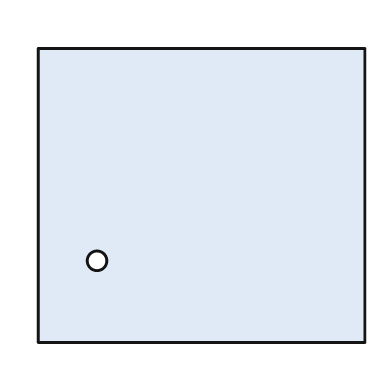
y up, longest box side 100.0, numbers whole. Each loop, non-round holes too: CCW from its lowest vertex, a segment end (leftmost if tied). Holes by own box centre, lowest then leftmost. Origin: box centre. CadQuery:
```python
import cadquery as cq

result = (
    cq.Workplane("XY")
    .moveTo(-50.0, -45.0)
    .lineTo(50.0, -45.0)
    .lineTo(50.0, 45.0)
    .lineTo(-50.0, 45.0)
    .close()
    .moveTo(-32.0, -20.0)
    .circle(3.0)
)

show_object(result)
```